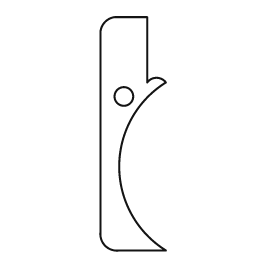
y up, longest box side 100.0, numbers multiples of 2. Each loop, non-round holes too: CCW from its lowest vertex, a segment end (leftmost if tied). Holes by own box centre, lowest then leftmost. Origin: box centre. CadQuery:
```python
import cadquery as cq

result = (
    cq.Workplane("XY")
    .moveTo(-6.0, -50.0)
    .lineTo(14.0, -50.0)
    .threePointArc((-6.0, -14.0), (14.0, 22.0))
    .threePointArc((10.0, 24.0), (6.0, 22.0))
    .lineTo(6.0, 50.0)
    .lineTo(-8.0, 50.0)
    .threePointArc((-12.0, 48.0), (-14.0, 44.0))
    .lineTo(-14.0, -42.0)
    .threePointArc((-12.0, -48.0), (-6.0, -50.0))
    .close()
    .moveTo(-4.0, 16.0)
    .circle(4.0)
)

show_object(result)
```